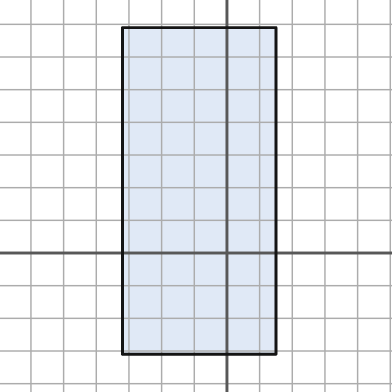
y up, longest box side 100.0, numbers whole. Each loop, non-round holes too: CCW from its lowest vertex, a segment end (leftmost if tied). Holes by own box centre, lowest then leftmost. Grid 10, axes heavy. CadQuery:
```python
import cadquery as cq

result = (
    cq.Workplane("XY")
    .moveTo(-32.0, -31.0)
    .lineTo(15.0, -31.0)
    .lineTo(15.0, 69.0)
    .lineTo(-32.0, 69.0)
    .close()
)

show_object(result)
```